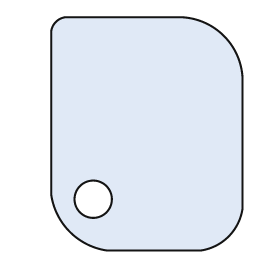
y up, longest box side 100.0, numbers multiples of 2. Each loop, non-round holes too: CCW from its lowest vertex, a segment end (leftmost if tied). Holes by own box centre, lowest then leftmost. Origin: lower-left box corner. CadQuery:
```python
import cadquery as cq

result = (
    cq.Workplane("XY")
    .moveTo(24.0, 0.0)
    .lineTo(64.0, 0.0)
    .threePointArc((76.0, 6.0), (82.0, 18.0))
    .lineTo(82.0, 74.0)
    .threePointArc((74.0, 92.0), (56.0, 100.0))
    .lineTo(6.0, 100.0)
    .threePointArc((2.0, 98.0), (0.0, 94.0))
    .lineTo(0.0, 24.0)
    .threePointArc((8.0, 8.0), (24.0, 0.0))
    .close()
    .moveTo(18.0, 22.0)
    .circle(8.0)
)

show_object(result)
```